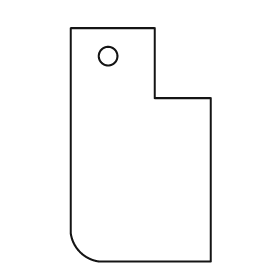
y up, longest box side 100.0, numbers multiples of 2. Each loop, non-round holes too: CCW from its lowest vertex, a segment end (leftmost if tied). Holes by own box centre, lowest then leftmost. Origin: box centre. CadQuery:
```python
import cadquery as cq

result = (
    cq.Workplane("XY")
    .moveTo(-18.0, -50.0)
    .lineTo(30.0, -50.0)
    .lineTo(30.0, 20.0)
    .lineTo(6.0, 20.0)
    .lineTo(6.0, 50.0)
    .lineTo(-30.0, 50.0)
    .lineTo(-30.0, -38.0)
    .threePointArc((-26.0, -46.0), (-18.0, -50.0))
    .close()
    .moveTo(-14.0, 38.0)
    .circle(4.0)
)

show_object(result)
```